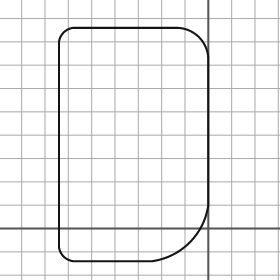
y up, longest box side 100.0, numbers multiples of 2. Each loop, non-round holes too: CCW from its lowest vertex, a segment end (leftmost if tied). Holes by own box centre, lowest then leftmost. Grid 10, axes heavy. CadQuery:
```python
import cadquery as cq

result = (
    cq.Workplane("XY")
    .moveTo(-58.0, -14.0)
    .lineTo(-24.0, -14.0)
    .threePointArc((-8.0, -6.0), (0.0, 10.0))
    .lineTo(0.0, 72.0)
    .threePointArc((-4.0, 82.0), (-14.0, 86.0))
    .lineTo(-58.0, 86.0)
    .threePointArc((-62.0, 84.0), (-64.0, 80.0))
    .lineTo(-64.0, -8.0)
    .threePointArc((-62.0, -12.0), (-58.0, -14.0))
    .close()
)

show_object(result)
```